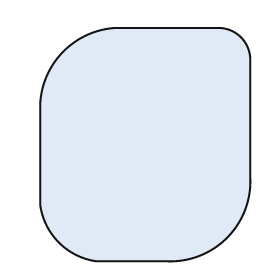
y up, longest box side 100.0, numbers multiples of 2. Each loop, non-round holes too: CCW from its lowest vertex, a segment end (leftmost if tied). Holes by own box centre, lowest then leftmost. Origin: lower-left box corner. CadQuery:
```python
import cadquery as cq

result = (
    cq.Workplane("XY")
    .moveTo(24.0, 0.0)
    .lineTo(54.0, 0.0)
    .threePointArc((80.0, 10.0), (90.0, 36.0))
    .lineTo(90.0, 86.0)
    .threePointArc((86.0, 96.0), (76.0, 100.0))
    .lineTo(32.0, 100.0)
    .threePointArc((10.0, 90.0), (0.0, 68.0))
    .lineTo(0.0, 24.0)
    .threePointArc((8.0, 8.0), (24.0, 0.0))
    .close()
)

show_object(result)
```